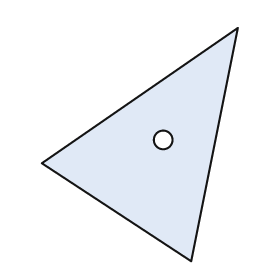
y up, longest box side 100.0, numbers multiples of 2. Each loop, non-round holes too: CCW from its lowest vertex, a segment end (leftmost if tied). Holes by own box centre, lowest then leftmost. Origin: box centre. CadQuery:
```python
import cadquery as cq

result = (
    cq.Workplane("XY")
    .moveTo(22.0, -50.0)
    .lineTo(42.0, 50.0)
    .lineTo(-42.0, -8.0)
    .close()
    .moveTo(10.0, 2.0)
    .circle(4.0)
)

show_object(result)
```